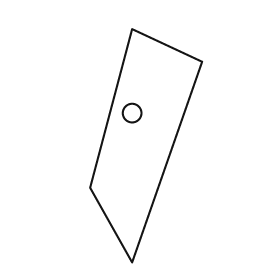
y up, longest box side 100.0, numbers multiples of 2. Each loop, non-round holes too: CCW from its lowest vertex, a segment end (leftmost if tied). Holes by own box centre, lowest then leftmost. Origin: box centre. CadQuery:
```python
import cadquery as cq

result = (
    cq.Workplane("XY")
    .moveTo(-6.0, -50.0)
    .lineTo(24.0, 36.0)
    .lineTo(-6.0, 50.0)
    .lineTo(-24.0, -18.0)
    .close()
    .moveTo(-6.0, 14.0)
    .circle(4.0)
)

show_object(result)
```